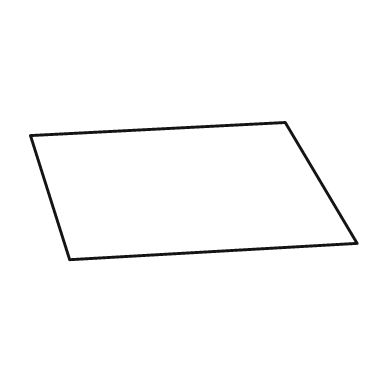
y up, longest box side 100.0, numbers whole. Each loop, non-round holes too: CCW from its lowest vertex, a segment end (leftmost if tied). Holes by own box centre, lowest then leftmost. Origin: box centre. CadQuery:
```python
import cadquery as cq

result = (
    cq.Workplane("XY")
    .moveTo(-38.0, -21.0)
    .lineTo(50.0, -16.0)
    .lineTo(28.0, 21.0)
    .lineTo(-50.0, 17.0)
    .close()
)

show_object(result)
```